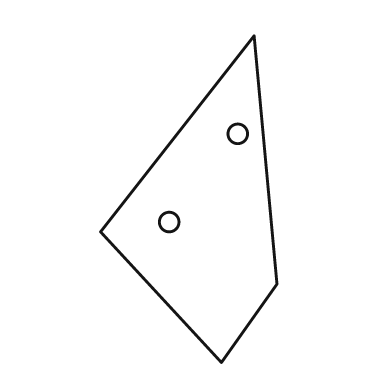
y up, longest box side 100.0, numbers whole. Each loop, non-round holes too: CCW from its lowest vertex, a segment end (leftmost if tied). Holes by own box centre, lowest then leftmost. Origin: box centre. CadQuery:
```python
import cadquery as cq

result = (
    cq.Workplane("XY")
    .moveTo(10.0, -50.0)
    .lineTo(27.0, -26.0)
    .lineTo(20.0, 50.0)
    .lineTo(-27.0, -10.0)
    .close()
    .moveTo(-6.0, -7.0)
    .circle(3.0)
    .moveTo(15.0, 20.0)
    .circle(3.0)
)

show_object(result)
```